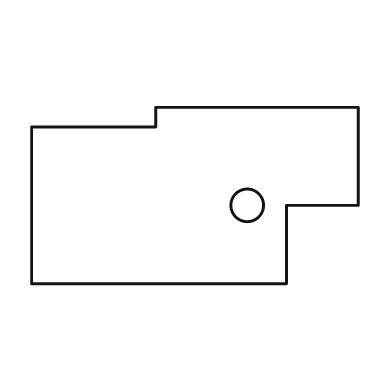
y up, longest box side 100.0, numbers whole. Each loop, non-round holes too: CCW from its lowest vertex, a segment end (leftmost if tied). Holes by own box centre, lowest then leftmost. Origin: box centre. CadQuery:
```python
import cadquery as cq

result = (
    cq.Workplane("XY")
    .moveTo(-50.0, -27.0)
    .lineTo(28.0, -27.0)
    .lineTo(28.0, -3.0)
    .lineTo(50.0, -3.0)
    .lineTo(50.0, 27.0)
    .lineTo(-12.0, 27.0)
    .lineTo(-12.0, 21.0)
    .lineTo(-50.0, 21.0)
    .close()
    .moveTo(16.0, -3.0)
    .circle(5.0)
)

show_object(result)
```